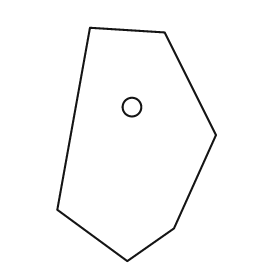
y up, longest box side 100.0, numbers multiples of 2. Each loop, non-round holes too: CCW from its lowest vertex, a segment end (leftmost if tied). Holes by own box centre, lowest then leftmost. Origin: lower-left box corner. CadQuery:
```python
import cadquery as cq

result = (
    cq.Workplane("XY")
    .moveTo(30.0, 0.0)
    .lineTo(50.0, 14.0)
    .lineTo(68.0, 54.0)
    .lineTo(46.0, 98.0)
    .lineTo(14.0, 100.0)
    .lineTo(0.0, 22.0)
    .close()
    .moveTo(32.0, 66.0)
    .circle(4.0)
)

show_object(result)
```